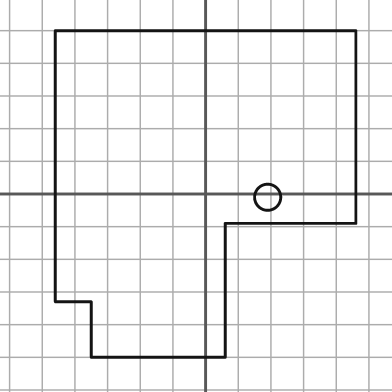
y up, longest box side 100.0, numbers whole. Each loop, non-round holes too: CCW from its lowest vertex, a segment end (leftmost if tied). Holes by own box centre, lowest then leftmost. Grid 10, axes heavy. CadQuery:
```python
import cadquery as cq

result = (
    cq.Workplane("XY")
    .moveTo(-35.0, -50.0)
    .lineTo(6.0, -50.0)
    .lineTo(6.0, -9.0)
    .lineTo(46.0, -9.0)
    .lineTo(46.0, 50.0)
    .lineTo(-46.0, 50.0)
    .lineTo(-46.0, -33.0)
    .lineTo(-35.0, -33.0)
    .close()
    .moveTo(19.0, -1.0)
    .circle(4.0)
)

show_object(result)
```